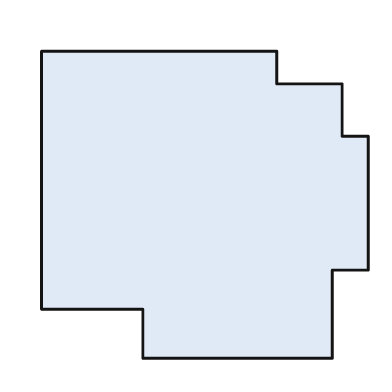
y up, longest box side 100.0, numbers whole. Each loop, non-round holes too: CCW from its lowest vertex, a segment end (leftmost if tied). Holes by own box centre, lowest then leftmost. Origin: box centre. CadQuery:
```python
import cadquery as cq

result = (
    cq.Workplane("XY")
    .moveTo(-19.0, -47.0)
    .lineTo(39.0, -47.0)
    .lineTo(39.0, -20.0)
    .lineTo(50.0, -20.0)
    .lineTo(50.0, 21.0)
    .lineTo(42.0, 21.0)
    .lineTo(42.0, 37.0)
    .lineTo(22.0, 37.0)
    .lineTo(22.0, 47.0)
    .lineTo(-50.0, 47.0)
    .lineTo(-50.0, -32.0)
    .lineTo(-19.0, -32.0)
    .close()
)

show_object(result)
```